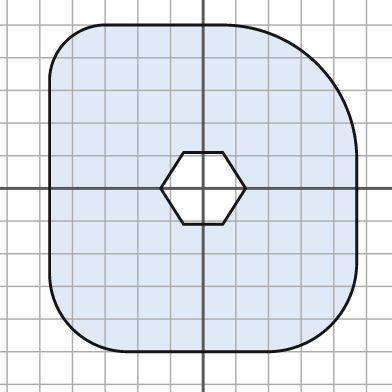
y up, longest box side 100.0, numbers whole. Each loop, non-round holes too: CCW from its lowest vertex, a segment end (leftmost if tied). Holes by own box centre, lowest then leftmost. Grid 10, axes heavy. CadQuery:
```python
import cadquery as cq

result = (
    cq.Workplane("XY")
    .moveTo(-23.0, -50.0)
    .lineTo(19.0, -50.0)
    .threePointArc((39.0, -42.0), (47.0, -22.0))
    .lineTo(47.0, 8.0)
    .threePointArc((35.0, 38.0), (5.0, 50.0))
    .lineTo(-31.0, 50.0)
    .threePointArc((-42.0, 45.0), (-47.0, 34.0))
    .lineTo(-47.0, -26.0)
    .threePointArc((-40.0, -43.0), (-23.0, -50.0))
    .close()
    .moveTo(-6.0, -11.0)
    .lineTo(6.0, -11.0)
    .lineTo(13.0, 0.0)
    .lineTo(6.0, 11.0)
    .lineTo(-6.0, 11.0)
    .lineTo(-13.0, 0.0)
    .close()
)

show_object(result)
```